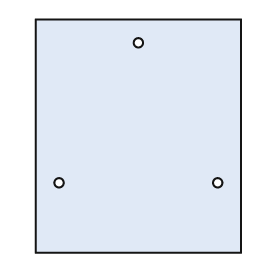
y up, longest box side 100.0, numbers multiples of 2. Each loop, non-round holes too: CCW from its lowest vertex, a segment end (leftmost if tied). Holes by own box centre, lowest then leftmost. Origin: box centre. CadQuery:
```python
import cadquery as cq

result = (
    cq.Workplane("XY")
    .moveTo(-44.0, -50.0)
    .lineTo(44.0, -50.0)
    .lineTo(44.0, 50.0)
    .lineTo(-44.0, 50.0)
    .close()
    .moveTo(-34.0, -20.0)
    .circle(2.0)
    .moveTo(34.0, -20.0)
    .circle(2.0)
    .moveTo(0.0, 40.0)
    .circle(2.0)
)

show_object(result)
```